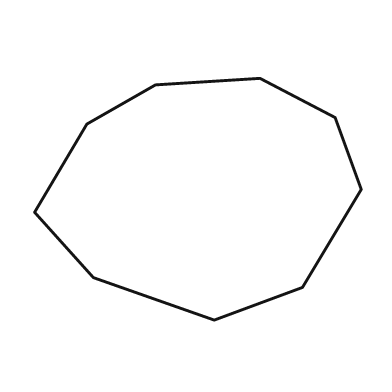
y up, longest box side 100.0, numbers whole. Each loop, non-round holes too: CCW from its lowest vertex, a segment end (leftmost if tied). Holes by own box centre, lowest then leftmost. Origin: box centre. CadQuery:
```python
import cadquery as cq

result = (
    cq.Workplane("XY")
    .moveTo(5.0, -37.0)
    .lineTo(32.0, -27.0)
    .lineTo(50.0, 3.0)
    .lineTo(42.0, 25.0)
    .lineTo(19.0, 37.0)
    .lineTo(-13.0, 35.0)
    .lineTo(-34.0, 23.0)
    .lineTo(-50.0, -4.0)
    .lineTo(-32.0, -24.0)
    .close()
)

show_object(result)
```